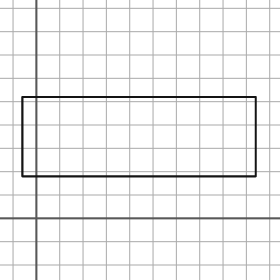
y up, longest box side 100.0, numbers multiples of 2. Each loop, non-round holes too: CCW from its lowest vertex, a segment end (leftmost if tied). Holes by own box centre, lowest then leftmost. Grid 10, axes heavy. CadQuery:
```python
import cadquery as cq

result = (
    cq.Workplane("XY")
    .moveTo(-6.0, 18.0)
    .lineTo(94.0, 18.0)
    .lineTo(94.0, 52.0)
    .lineTo(-6.0, 52.0)
    .close()
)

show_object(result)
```